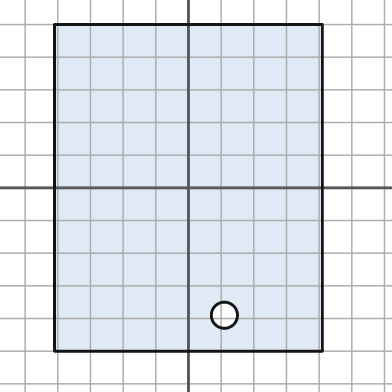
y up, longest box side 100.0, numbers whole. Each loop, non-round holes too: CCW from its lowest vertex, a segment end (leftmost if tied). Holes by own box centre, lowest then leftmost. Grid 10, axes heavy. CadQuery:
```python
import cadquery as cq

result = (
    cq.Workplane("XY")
    .moveTo(-41.0, -50.0)
    .lineTo(41.0, -50.0)
    .lineTo(41.0, 50.0)
    .lineTo(-41.0, 50.0)
    .close()
    .moveTo(11.0, -39.0)
    .circle(4.0)
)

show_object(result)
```